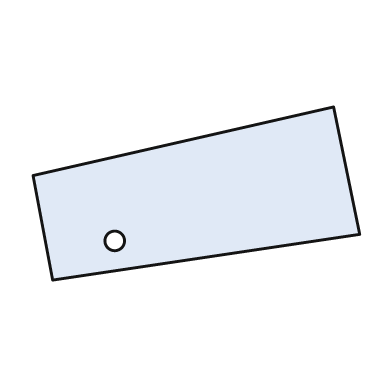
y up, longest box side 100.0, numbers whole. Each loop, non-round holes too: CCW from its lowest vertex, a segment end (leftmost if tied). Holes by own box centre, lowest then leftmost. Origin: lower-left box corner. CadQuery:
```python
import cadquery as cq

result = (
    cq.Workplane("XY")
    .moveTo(6.0, 0.0)
    .lineTo(100.0, 14.0)
    .lineTo(92.0, 53.0)
    .lineTo(0.0, 32.0)
    .close()
    .moveTo(25.0, 12.0)
    .circle(3.0)
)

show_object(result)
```